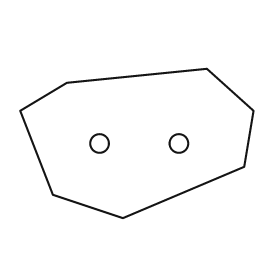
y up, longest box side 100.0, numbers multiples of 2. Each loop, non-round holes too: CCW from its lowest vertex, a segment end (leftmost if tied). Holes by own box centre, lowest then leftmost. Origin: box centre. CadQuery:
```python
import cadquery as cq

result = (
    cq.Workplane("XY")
    .moveTo(-6.0, -32.0)
    .lineTo(46.0, -10.0)
    .lineTo(50.0, 14.0)
    .lineTo(30.0, 32.0)
    .lineTo(-30.0, 26.0)
    .lineTo(-50.0, 14.0)
    .lineTo(-36.0, -22.0)
    .close()
    .moveTo(-16.0, 0.0)
    .circle(4.0)
    .moveTo(18.0, 0.0)
    .circle(4.0)
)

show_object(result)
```